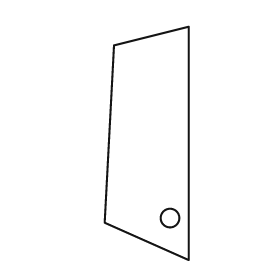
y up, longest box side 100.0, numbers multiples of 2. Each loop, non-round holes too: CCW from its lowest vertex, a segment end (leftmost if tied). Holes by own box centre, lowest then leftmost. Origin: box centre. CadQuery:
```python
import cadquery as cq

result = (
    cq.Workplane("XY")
    .moveTo(18.0, -50.0)
    .lineTo(18.0, 50.0)
    .lineTo(-14.0, 42.0)
    .lineTo(-18.0, -34.0)
    .close()
    .moveTo(10.0, -32.0)
    .circle(4.0)
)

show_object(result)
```